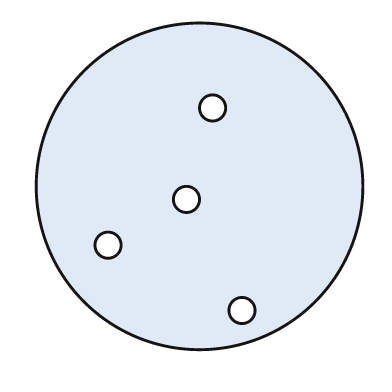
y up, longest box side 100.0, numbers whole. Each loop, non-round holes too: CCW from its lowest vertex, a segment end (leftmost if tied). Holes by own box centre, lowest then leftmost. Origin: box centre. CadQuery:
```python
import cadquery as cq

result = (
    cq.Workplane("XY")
    .moveTo(0.0, 0.0)
    .circle(50.0)
    .moveTo(13.0, -38.0)
    .circle(4.0)
    .moveTo(-28.0, -18.0)
    .circle(4.0)
    .moveTo(-4.0, -4.0)
    .circle(4.0)
    .moveTo(4.0, 24.0)
    .circle(4.0)
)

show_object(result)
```